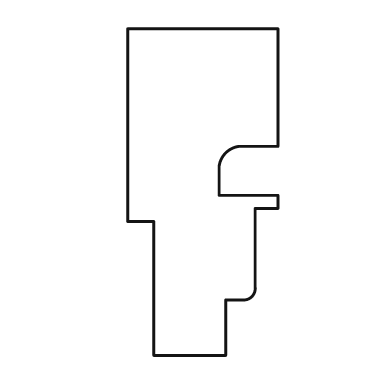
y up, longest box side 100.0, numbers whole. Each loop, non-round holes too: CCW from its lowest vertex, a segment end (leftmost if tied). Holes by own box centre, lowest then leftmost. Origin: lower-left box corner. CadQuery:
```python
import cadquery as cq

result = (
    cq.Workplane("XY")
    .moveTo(8.0, 0.0)
    .lineTo(30.0, 0.0)
    .lineTo(30.0, 17.0)
    .lineTo(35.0, 17.0)
    .threePointArc((38.0, 18.0), (39.0, 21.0))
    .lineTo(39.0, 45.0)
    .lineTo(46.0, 45.0)
    .lineTo(46.0, 49.0)
    .lineTo(28.0, 49.0)
    .lineTo(28.0, 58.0)
    .threePointArc((30.0, 62.0), (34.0, 64.0))
    .lineTo(46.0, 64.0)
    .lineTo(46.0, 100.0)
    .lineTo(0.0, 100.0)
    .lineTo(0.0, 41.0)
    .lineTo(8.0, 41.0)
    .close()
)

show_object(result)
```